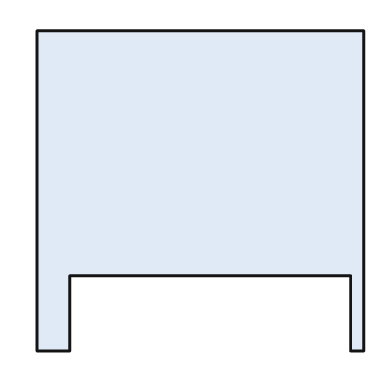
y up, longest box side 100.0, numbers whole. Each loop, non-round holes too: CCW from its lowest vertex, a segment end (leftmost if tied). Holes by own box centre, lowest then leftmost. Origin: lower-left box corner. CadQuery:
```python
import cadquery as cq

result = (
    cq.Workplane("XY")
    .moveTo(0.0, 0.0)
    .lineTo(10.0, 0.0)
    .lineTo(10.0, 23.0)
    .lineTo(96.0, 23.0)
    .lineTo(96.0, 0.0)
    .lineTo(100.0, 0.0)
    .lineTo(100.0, 98.0)
    .lineTo(0.0, 98.0)
    .close()
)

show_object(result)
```